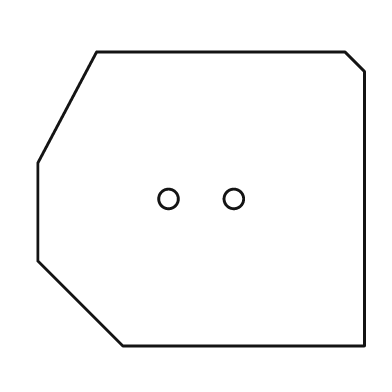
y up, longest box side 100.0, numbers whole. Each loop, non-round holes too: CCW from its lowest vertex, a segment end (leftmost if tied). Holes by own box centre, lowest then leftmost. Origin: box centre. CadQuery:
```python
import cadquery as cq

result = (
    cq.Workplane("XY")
    .moveTo(-24.0, -45.0)
    .lineTo(50.0, -45.0)
    .lineTo(50.0, 39.0)
    .lineTo(44.0, 45.0)
    .lineTo(-32.0, 45.0)
    .lineTo(-50.0, 11.0)
    .lineTo(-50.0, -19.0)
    .close()
    .moveTo(-10.0, 0.0)
    .circle(3.0)
    .moveTo(10.0, 0.0)
    .circle(3.0)
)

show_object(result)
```